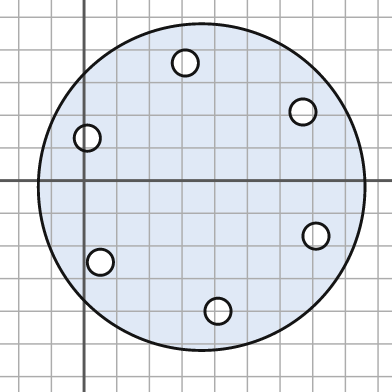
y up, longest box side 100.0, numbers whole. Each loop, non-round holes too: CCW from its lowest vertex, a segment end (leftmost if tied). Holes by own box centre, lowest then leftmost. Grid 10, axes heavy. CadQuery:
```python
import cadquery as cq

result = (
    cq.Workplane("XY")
    .moveTo(36.0, -2.0)
    .circle(50.0)
    .moveTo(41.0, -40.0)
    .circle(4.0)
    .moveTo(5.0, -25.0)
    .circle(4.0)
    .moveTo(71.0, -17.0)
    .circle(4.0)
    .moveTo(1.0, 13.0)
    .circle(4.0)
    .moveTo(67.0, 21.0)
    .circle(4.0)
    .moveTo(31.0, 36.0)
    .circle(4.0)
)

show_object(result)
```